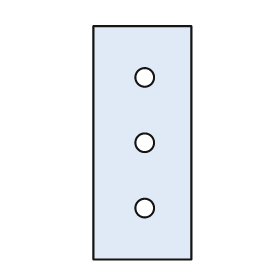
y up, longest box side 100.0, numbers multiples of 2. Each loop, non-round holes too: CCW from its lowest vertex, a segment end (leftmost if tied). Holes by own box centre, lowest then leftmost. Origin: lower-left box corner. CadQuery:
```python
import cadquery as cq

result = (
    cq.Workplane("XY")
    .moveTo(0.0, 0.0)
    .lineTo(42.0, 0.0)
    .lineTo(42.0, 100.0)
    .lineTo(0.0, 100.0)
    .close()
    .moveTo(22.0, 22.0)
    .circle(4.0)
    .moveTo(22.0, 50.0)
    .circle(4.0)
    .moveTo(22.0, 78.0)
    .circle(4.0)
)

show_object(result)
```